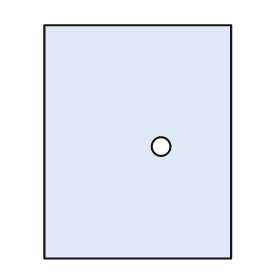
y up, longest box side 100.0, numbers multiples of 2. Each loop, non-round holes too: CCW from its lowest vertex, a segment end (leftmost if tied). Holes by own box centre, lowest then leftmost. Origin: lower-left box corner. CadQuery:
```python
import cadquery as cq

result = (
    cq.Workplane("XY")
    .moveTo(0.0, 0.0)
    .lineTo(80.0, 0.0)
    .lineTo(80.0, 100.0)
    .lineTo(0.0, 100.0)
    .close()
    .moveTo(50.0, 48.0)
    .circle(4.0)
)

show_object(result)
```